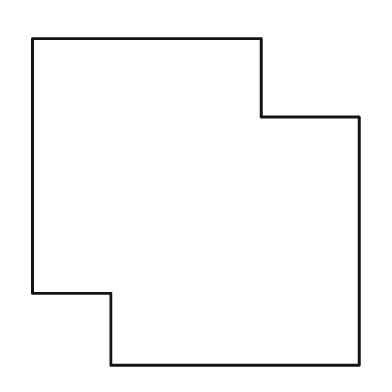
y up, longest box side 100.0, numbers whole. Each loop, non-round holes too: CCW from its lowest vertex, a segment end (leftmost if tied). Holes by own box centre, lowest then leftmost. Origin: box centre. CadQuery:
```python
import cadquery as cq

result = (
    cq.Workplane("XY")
    .moveTo(-26.0, -50.0)
    .lineTo(50.0, -50.0)
    .lineTo(50.0, 26.0)
    .lineTo(20.0, 26.0)
    .lineTo(20.0, 50.0)
    .lineTo(-50.0, 50.0)
    .lineTo(-50.0, -28.0)
    .lineTo(-26.0, -28.0)
    .close()
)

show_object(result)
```